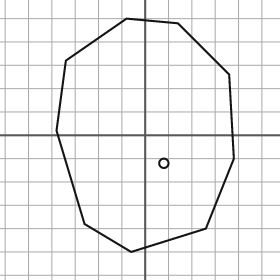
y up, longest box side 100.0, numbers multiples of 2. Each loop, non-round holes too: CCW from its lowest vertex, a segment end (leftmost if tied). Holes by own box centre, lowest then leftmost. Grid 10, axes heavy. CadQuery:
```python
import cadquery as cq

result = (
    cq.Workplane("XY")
    .moveTo(-6.0, -50.0)
    .lineTo(26.0, -40.0)
    .lineTo(38.0, -10.0)
    .lineTo(36.0, 26.0)
    .lineTo(14.0, 48.0)
    .lineTo(-8.0, 50.0)
    .lineTo(-34.0, 32.0)
    .lineTo(-38.0, 2.0)
    .lineTo(-26.0, -38.0)
    .close()
    .moveTo(8.0, -12.0)
    .circle(2.0)
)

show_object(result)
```